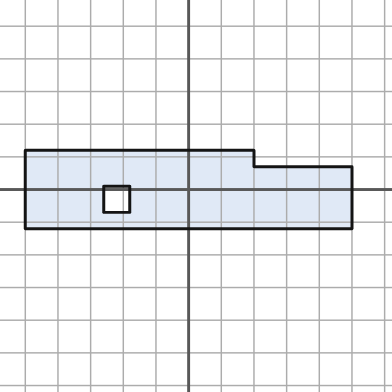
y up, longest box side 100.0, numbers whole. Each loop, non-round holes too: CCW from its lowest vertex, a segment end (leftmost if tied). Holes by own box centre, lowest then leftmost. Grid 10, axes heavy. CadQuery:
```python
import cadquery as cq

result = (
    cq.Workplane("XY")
    .moveTo(-50.0, -12.0)
    .lineTo(50.0, -12.0)
    .lineTo(50.0, 7.0)
    .lineTo(20.0, 7.0)
    .lineTo(20.0, 12.0)
    .lineTo(-50.0, 12.0)
    .close()
    .moveTo(-26.0, -7.0)
    .lineTo(-18.0, -7.0)
    .lineTo(-18.0, 1.0)
    .lineTo(-26.0, 1.0)
    .close()
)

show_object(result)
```